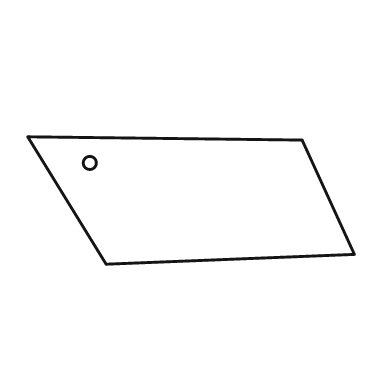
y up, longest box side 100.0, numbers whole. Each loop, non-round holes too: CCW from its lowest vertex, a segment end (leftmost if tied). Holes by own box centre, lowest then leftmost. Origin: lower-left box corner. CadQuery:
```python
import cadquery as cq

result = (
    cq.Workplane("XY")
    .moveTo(24.0, 0.0)
    .lineTo(100.0, 3.0)
    .lineTo(84.0, 38.0)
    .lineTo(0.0, 39.0)
    .close()
    .moveTo(19.0, 31.0)
    .circle(2.0)
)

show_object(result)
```